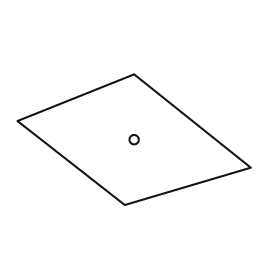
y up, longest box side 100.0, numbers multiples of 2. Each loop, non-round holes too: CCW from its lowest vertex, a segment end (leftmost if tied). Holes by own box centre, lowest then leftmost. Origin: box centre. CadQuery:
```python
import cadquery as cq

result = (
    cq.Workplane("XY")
    .moveTo(-4.0, -28.0)
    .lineTo(50.0, -12.0)
    .lineTo(0.0, 28.0)
    .lineTo(-50.0, 8.0)
    .close()
    .moveTo(0.0, 0.0)
    .circle(2.0)
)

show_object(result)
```